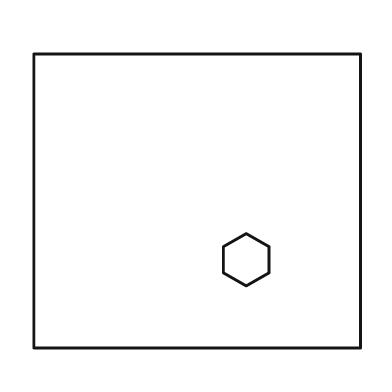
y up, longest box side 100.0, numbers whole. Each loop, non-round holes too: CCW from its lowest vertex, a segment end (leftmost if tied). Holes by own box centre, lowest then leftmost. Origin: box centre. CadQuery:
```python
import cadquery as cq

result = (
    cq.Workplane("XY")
    .moveTo(-50.0, -45.0)
    .lineTo(50.0, -45.0)
    .lineTo(50.0, 45.0)
    .lineTo(-50.0, 45.0)
    .close()
    .moveTo(15.0, -26.0)
    .lineTo(22.0, -22.0)
    .lineTo(22.0, -14.0)
    .lineTo(15.0, -10.0)
    .lineTo(8.0, -14.0)
    .lineTo(8.0, -22.0)
    .close()
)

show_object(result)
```